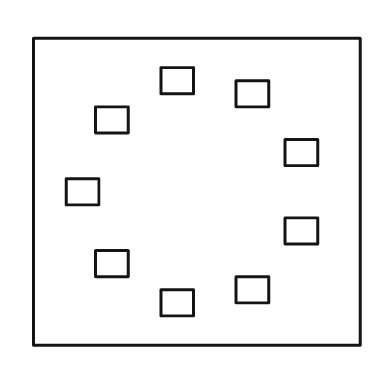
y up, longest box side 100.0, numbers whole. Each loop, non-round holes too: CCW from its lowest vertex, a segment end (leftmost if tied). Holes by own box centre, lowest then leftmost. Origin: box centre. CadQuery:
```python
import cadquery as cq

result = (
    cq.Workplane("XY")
    .moveTo(-50.0, -47.0)
    .lineTo(50.0, -47.0)
    .lineTo(50.0, 47.0)
    .lineTo(-50.0, 47.0)
    .close()
    .moveTo(-11.0, -38.0)
    .lineTo(-1.0, -38.0)
    .lineTo(-1.0, -30.0)
    .lineTo(-11.0, -30.0)
    .close()
    .moveTo(12.0, -34.0)
    .lineTo(22.0, -34.0)
    .lineTo(22.0, -26.0)
    .lineTo(12.0, -26.0)
    .close()
    .moveTo(-31.0, -26.0)
    .lineTo(-21.0, -26.0)
    .lineTo(-21.0, -18.0)
    .lineTo(-31.0, -18.0)
    .close()
    .moveTo(27.0, -16.0)
    .lineTo(37.0, -16.0)
    .lineTo(37.0, -8.0)
    .lineTo(27.0, -8.0)
    .close()
    .moveTo(-40.0, -4.0)
    .lineTo(-30.0, -4.0)
    .lineTo(-30.0, 4.0)
    .lineTo(-40.0, 4.0)
    .close()
    .moveTo(27.0, 8.0)
    .lineTo(37.0, 8.0)
    .lineTo(37.0, 16.0)
    .lineTo(27.0, 16.0)
    .close()
    .moveTo(-31.0, 18.0)
    .lineTo(-21.0, 18.0)
    .lineTo(-21.0, 26.0)
    .lineTo(-31.0, 26.0)
    .close()
    .moveTo(12.0, 26.0)
    .lineTo(22.0, 26.0)
    .lineTo(22.0, 34.0)
    .lineTo(12.0, 34.0)
    .close()
    .moveTo(-11.0, 30.0)
    .lineTo(-1.0, 30.0)
    .lineTo(-1.0, 38.0)
    .lineTo(-11.0, 38.0)
    .close()
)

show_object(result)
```